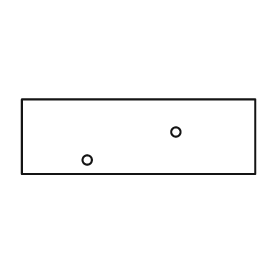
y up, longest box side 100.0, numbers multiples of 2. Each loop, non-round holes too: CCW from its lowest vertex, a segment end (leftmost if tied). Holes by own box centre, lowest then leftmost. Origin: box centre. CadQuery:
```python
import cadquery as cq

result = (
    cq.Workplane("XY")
    .moveTo(-50.0, -16.0)
    .lineTo(50.0, -16.0)
    .lineTo(50.0, 16.0)
    .lineTo(-50.0, 16.0)
    .close()
    .moveTo(-22.0, -10.0)
    .circle(2.0)
    .moveTo(16.0, 2.0)
    .circle(2.0)
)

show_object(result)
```